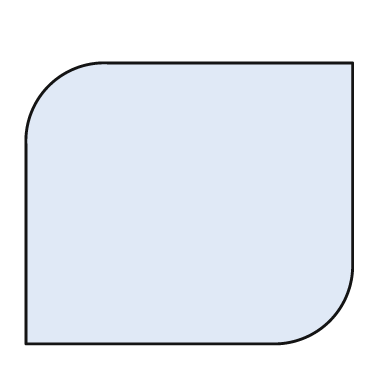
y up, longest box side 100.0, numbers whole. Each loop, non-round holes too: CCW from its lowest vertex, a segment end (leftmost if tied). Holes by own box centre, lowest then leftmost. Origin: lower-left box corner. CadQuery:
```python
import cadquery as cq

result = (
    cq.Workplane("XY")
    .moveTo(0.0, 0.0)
    .lineTo(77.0, 0.0)
    .threePointArc((93.0, 7.0), (100.0, 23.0))
    .lineTo(100.0, 86.0)
    .lineTo(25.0, 86.0)
    .threePointArc((7.0, 79.0), (0.0, 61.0))
    .close()
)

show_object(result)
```